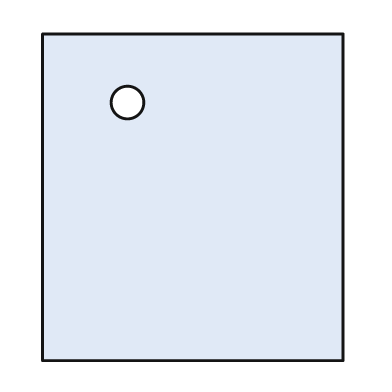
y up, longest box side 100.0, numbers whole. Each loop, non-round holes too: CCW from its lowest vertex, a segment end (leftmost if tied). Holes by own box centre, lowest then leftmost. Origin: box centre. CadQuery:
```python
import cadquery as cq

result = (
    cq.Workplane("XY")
    .moveTo(-46.0, -50.0)
    .lineTo(46.0, -50.0)
    .lineTo(46.0, 50.0)
    .lineTo(-46.0, 50.0)
    .close()
    .moveTo(-20.0, 29.0)
    .circle(5.0)
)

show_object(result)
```